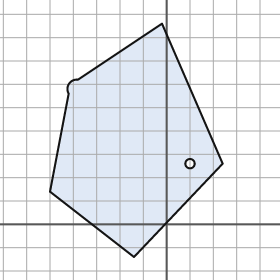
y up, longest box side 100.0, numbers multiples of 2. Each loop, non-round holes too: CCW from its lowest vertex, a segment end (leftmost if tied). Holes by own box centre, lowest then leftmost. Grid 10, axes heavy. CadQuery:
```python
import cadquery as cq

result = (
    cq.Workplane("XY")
    .moveTo(-14.0, -14.0)
    .lineTo(24.0, 26.0)
    .lineTo(-2.0, 86.0)
    .lineTo(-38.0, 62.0)
    .threePointArc((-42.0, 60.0), (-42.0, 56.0))
    .lineTo(-50.0, 14.0)
    .close()
    .moveTo(10.0, 26.0)
    .circle(2.0)
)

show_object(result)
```